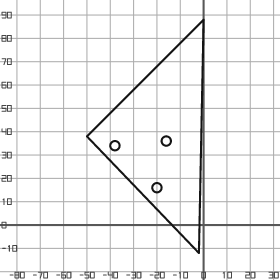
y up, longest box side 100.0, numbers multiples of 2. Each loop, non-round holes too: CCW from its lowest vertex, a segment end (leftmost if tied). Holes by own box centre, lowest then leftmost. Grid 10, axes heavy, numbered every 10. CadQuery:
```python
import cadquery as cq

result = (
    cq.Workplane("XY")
    .moveTo(-2.0, -12.0)
    .lineTo(0.0, 88.0)
    .lineTo(-50.0, 38.0)
    .close()
    .moveTo(-20.0, 16.0)
    .circle(2.0)
    .moveTo(-38.0, 34.0)
    .circle(2.0)
    .moveTo(-16.0, 36.0)
    .circle(2.0)
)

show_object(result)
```